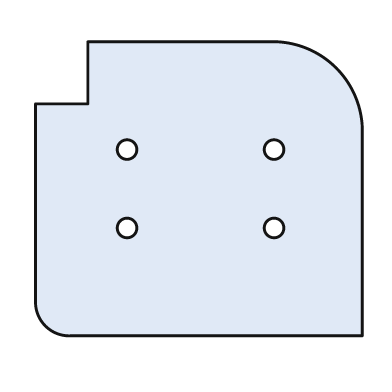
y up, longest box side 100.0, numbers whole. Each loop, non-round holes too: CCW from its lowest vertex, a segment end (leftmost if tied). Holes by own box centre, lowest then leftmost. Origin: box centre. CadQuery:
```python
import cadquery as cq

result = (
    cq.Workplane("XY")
    .moveTo(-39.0, -45.0)
    .lineTo(50.0, -45.0)
    .lineTo(50.0, 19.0)
    .threePointArc((42.0, 37.0), (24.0, 45.0))
    .lineTo(-34.0, 45.0)
    .lineTo(-34.0, 26.0)
    .lineTo(-50.0, 26.0)
    .lineTo(-50.0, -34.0)
    .threePointArc((-47.0, -42.0), (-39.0, -45.0))
    .close()
    .moveTo(-22.0, -12.0)
    .circle(3.0)
    .moveTo(23.0, -12.0)
    .circle(3.0)
    .moveTo(-22.0, 12.0)
    .circle(3.0)
    .moveTo(23.0, 12.0)
    .circle(3.0)
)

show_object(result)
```